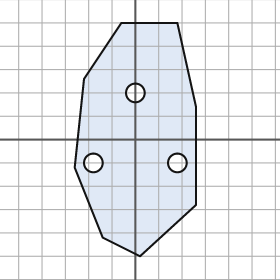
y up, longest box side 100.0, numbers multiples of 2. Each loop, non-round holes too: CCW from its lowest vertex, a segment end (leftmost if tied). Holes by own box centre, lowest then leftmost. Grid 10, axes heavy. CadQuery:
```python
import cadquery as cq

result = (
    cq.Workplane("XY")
    .moveTo(2.0, -50.0)
    .lineTo(26.0, -28.0)
    .lineTo(26.0, 14.0)
    .lineTo(18.0, 50.0)
    .lineTo(-6.0, 50.0)
    .lineTo(-22.0, 26.0)
    .lineTo(-26.0, -12.0)
    .lineTo(-14.0, -42.0)
    .close()
    .moveTo(-18.0, -10.0)
    .circle(4.0)
    .moveTo(18.0, -10.0)
    .circle(4.0)
    .moveTo(0.0, 20.0)
    .circle(4.0)
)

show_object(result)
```